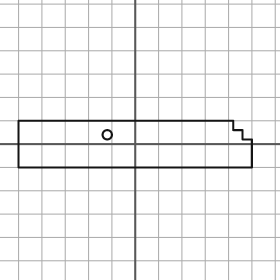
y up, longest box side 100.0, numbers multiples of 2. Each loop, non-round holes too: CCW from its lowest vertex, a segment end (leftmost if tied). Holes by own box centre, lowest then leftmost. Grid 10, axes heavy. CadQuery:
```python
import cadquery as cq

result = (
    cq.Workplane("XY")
    .moveTo(-50.0, -10.0)
    .lineTo(50.0, -10.0)
    .lineTo(50.0, 2.0)
    .lineTo(46.0, 2.0)
    .lineTo(46.0, 6.0)
    .lineTo(42.0, 6.0)
    .lineTo(42.0, 10.0)
    .lineTo(-50.0, 10.0)
    .close()
    .moveTo(-12.0, 4.0)
    .circle(2.0)
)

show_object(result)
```